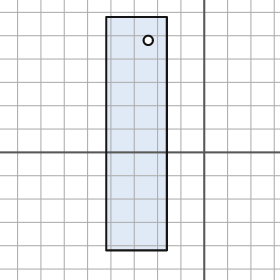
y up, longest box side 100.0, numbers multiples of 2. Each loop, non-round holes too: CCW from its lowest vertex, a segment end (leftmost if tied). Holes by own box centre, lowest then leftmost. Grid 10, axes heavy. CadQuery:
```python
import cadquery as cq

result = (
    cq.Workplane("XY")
    .moveTo(-42.0, -42.0)
    .lineTo(-16.0, -42.0)
    .lineTo(-16.0, 58.0)
    .lineTo(-42.0, 58.0)
    .close()
    .moveTo(-24.0, 48.0)
    .circle(2.0)
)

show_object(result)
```